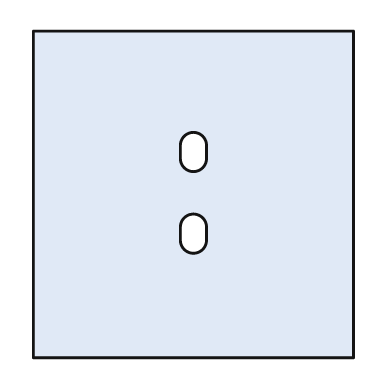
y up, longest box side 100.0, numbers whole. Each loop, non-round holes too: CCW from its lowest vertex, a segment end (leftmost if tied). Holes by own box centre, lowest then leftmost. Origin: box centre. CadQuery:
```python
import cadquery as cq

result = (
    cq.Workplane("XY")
    .moveTo(-49.0, -50.0)
    .lineTo(49.0, -50.0)
    .lineTo(49.0, 50.0)
    .lineTo(-49.0, 50.0)
    .close()
    .moveTo(-4.0, -14.0)
    .threePointArc((0.0, -18.0), (4.0, -14.0))
    .lineTo(4.0, -10.0)
    .threePointArc((0.0, -6.0), (-4.0, -10.0))
    .close()
    .moveTo(-4.0, 11.0)
    .threePointArc((0.0, 7.0), (4.0, 11.0))
    .lineTo(4.0, 15.0)
    .threePointArc((0.0, 19.0), (-4.0, 15.0))
    .close()
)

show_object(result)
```